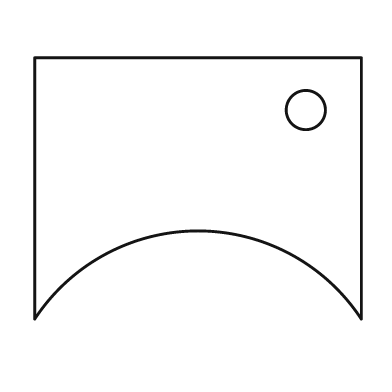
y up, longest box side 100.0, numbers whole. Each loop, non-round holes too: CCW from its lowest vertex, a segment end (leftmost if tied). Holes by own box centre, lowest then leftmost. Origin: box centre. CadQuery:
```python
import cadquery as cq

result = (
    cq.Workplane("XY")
    .moveTo(-50.0, -40.0)
    .threePointArc((0.0, -13.0), (50.0, -40.0))
    .lineTo(50.0, 40.0)
    .lineTo(-50.0, 40.0)
    .close()
    .moveTo(33.0, 24.0)
    .circle(6.0)
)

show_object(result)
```